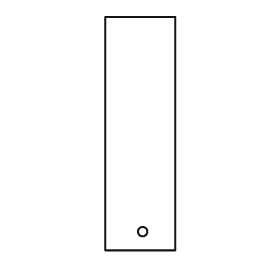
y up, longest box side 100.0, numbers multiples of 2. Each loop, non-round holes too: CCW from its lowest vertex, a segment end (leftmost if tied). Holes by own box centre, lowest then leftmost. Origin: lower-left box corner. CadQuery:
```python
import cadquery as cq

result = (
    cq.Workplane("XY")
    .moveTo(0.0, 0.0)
    .lineTo(30.0, 0.0)
    .lineTo(30.0, 100.0)
    .lineTo(0.0, 100.0)
    .close()
    .moveTo(16.0, 8.0)
    .circle(2.0)
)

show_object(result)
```